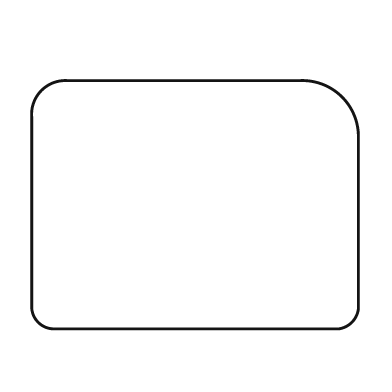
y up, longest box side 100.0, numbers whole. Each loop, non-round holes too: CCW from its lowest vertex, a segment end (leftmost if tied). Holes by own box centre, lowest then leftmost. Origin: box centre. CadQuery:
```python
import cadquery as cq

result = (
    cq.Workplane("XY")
    .moveTo(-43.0, -38.0)
    .lineTo(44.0, -38.0)
    .threePointArc((48.0, -36.0), (50.0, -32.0))
    .lineTo(50.0, 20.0)
    .threePointArc((45.0, 33.0), (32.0, 38.0))
    .lineTo(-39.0, 38.0)
    .threePointArc((-47.0, 35.0), (-50.0, 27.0))
    .lineTo(-50.0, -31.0)
    .threePointArc((-48.0, -36.0), (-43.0, -38.0))
    .close()
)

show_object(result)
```